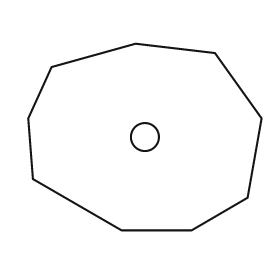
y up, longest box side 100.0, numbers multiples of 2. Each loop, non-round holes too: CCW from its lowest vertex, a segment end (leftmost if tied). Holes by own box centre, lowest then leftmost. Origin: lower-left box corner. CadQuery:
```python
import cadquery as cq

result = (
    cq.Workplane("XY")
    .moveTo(40.0, 0.0)
    .lineTo(70.0, 0.0)
    .lineTo(94.0, 14.0)
    .lineTo(100.0, 48.0)
    .lineTo(80.0, 76.0)
    .lineTo(46.0, 80.0)
    .lineTo(10.0, 70.0)
    .lineTo(0.0, 48.0)
    .lineTo(2.0, 22.0)
    .close()
    .moveTo(50.0, 40.0)
    .circle(6.0)
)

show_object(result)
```